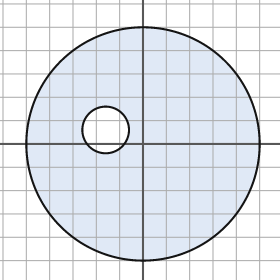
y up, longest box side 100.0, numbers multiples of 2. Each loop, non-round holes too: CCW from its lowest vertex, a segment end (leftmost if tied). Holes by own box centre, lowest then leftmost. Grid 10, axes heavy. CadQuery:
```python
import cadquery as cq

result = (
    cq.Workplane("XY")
    .moveTo(0.0, 0.0)
    .circle(50.0)
    .moveTo(-16.0, 6.0)
    .circle(10.0)
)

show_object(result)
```